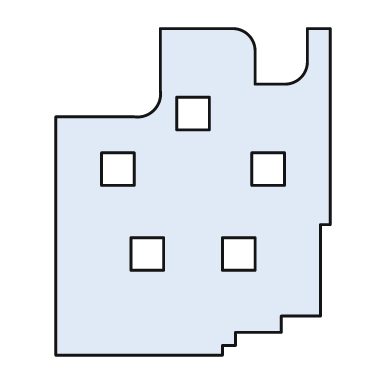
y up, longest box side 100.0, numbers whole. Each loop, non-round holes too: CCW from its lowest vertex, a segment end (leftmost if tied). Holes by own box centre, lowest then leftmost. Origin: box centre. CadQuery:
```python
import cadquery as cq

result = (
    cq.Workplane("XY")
    .moveTo(-42.0, -50.0)
    .lineTo(9.0, -50.0)
    .lineTo(9.0, -47.0)
    .lineTo(13.0, -47.0)
    .lineTo(13.0, -43.0)
    .lineTo(27.0, -43.0)
    .lineTo(27.0, -38.0)
    .lineTo(39.0, -38.0)
    .lineTo(39.0, -10.0)
    .lineTo(42.0, -10.0)
    .lineTo(42.0, 50.0)
    .lineTo(35.0, 50.0)
    .lineTo(35.0, 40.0)
    .threePointArc((33.0, 35.0), (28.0, 33.0))
    .lineTo(19.0, 33.0)
    .lineTo(19.0, 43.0)
    .threePointArc((17.0, 48.0), (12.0, 50.0))
    .lineTo(-10.0, 50.0)
    .lineTo(-10.0, 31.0)
    .threePointArc((-12.0, 25.0), (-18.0, 23.0))
    .lineTo(-42.0, 23.0)
    .close()
    .moveTo(-19.0, -24.0)
    .lineTo(-9.0, -24.0)
    .lineTo(-9.0, -14.0)
    .lineTo(-19.0, -14.0)
    .close()
    .moveTo(9.0, -24.0)
    .lineTo(19.0, -24.0)
    .lineTo(19.0, -14.0)
    .lineTo(9.0, -14.0)
    .close()
    .moveTo(-28.0, 2.0)
    .lineTo(-18.0, 2.0)
    .lineTo(-18.0, 12.0)
    .lineTo(-28.0, 12.0)
    .close()
    .moveTo(18.0, 2.0)
    .lineTo(28.0, 2.0)
    .lineTo(28.0, 12.0)
    .lineTo(18.0, 12.0)
    .close()
    .moveTo(-5.0, 19.0)
    .lineTo(5.0, 19.0)
    .lineTo(5.0, 29.0)
    .lineTo(-5.0, 29.0)
    .close()
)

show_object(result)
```